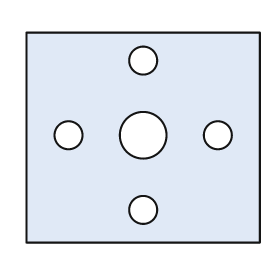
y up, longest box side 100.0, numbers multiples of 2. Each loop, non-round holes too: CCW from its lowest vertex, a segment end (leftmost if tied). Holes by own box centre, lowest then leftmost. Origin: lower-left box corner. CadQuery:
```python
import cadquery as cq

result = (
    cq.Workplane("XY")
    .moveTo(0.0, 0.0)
    .lineTo(100.0, 0.0)
    .lineTo(100.0, 90.0)
    .lineTo(0.0, 90.0)
    .close()
    .moveTo(50.0, 14.0)
    .circle(6.0)
    .moveTo(18.0, 46.0)
    .circle(6.0)
    .moveTo(50.0, 46.0)
    .circle(10.0)
    .moveTo(82.0, 46.0)
    .circle(6.0)
    .moveTo(50.0, 78.0)
    .circle(6.0)
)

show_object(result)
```